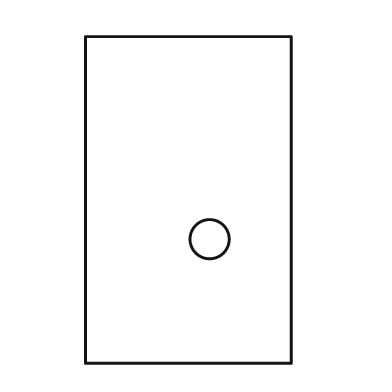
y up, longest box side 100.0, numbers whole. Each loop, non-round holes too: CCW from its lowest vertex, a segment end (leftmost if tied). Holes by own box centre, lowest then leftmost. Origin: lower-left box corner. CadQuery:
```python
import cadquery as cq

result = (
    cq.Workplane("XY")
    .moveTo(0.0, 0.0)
    .lineTo(63.0, 0.0)
    .lineTo(63.0, 100.0)
    .lineTo(0.0, 100.0)
    .close()
    .moveTo(38.0, 38.0)
    .circle(6.0)
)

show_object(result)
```